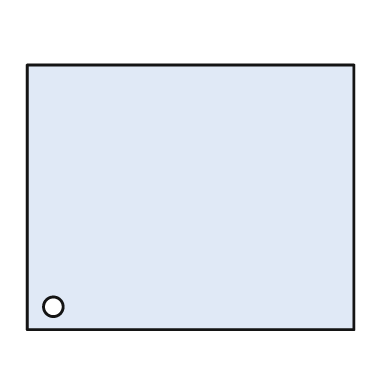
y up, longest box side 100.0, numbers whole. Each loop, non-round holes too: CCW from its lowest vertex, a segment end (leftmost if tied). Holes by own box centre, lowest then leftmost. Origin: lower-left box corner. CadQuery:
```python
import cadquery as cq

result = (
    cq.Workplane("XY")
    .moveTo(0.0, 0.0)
    .lineTo(100.0, 0.0)
    .lineTo(100.0, 81.0)
    .lineTo(0.0, 81.0)
    .close()
    .moveTo(8.0, 7.0)
    .circle(3.0)
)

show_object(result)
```